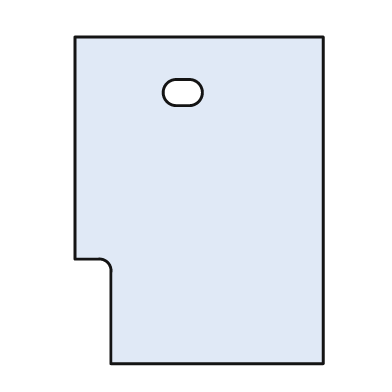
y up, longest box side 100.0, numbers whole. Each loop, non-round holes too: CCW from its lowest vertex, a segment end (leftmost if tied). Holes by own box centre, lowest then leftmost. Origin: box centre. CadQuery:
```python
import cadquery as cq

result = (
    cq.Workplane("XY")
    .moveTo(-27.0, -50.0)
    .lineTo(38.0, -50.0)
    .lineTo(38.0, 50.0)
    .lineTo(-38.0, 50.0)
    .lineTo(-38.0, -18.0)
    .lineTo(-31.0, -18.0)
    .threePointArc((-28.0, -19.0), (-27.0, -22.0))
    .close()
    .moveTo(-7.0, 29.0)
    .lineTo(-3.0, 29.0)
    .threePointArc((1.0, 33.0), (-3.0, 37.0))
    .lineTo(-7.0, 37.0)
    .threePointArc((-11.0, 33.0), (-7.0, 29.0))
    .close()
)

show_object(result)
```